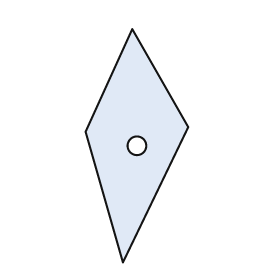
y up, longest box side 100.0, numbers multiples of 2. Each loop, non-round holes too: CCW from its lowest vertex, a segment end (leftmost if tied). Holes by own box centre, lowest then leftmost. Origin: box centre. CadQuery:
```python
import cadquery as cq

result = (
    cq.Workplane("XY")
    .moveTo(-6.0, -50.0)
    .lineTo(22.0, 8.0)
    .lineTo(-2.0, 50.0)
    .lineTo(-22.0, 6.0)
    .close()
    .moveTo(0.0, 0.0)
    .circle(4.0)
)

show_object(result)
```